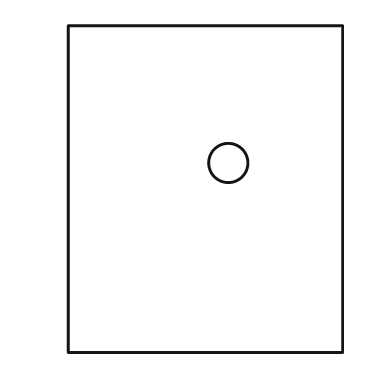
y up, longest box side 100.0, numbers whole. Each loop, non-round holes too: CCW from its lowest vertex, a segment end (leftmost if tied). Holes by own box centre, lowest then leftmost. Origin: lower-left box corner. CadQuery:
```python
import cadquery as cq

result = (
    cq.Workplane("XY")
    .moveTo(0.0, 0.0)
    .lineTo(84.0, 0.0)
    .lineTo(84.0, 100.0)
    .lineTo(0.0, 100.0)
    .close()
    .moveTo(49.0, 58.0)
    .circle(6.0)
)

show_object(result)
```